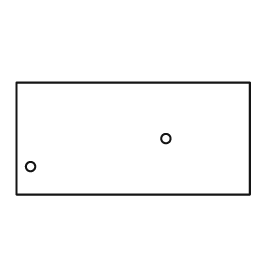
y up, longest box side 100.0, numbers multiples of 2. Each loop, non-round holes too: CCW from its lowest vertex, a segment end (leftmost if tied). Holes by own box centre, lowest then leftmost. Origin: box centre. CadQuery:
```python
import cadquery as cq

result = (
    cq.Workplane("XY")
    .moveTo(-50.0, -24.0)
    .lineTo(50.0, -24.0)
    .lineTo(50.0, 24.0)
    .lineTo(-50.0, 24.0)
    .close()
    .moveTo(-44.0, -12.0)
    .circle(2.0)
    .moveTo(14.0, 0.0)
    .circle(2.0)
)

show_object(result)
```